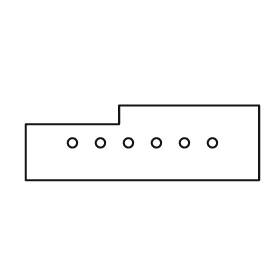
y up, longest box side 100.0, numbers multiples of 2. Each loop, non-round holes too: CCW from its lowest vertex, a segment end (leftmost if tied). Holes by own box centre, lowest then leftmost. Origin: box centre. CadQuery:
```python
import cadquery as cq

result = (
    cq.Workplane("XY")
    .moveTo(-50.0, -16.0)
    .lineTo(50.0, -16.0)
    .lineTo(50.0, 16.0)
    .lineTo(-10.0, 16.0)
    .lineTo(-10.0, 8.0)
    .lineTo(-50.0, 8.0)
    .close()
    .moveTo(-30.0, 0.0)
    .circle(2.0)
    .moveTo(-18.0, 0.0)
    .circle(2.0)
    .moveTo(-6.0, 0.0)
    .circle(2.0)
    .moveTo(6.0, 0.0)
    .circle(2.0)
    .moveTo(18.0, 0.0)
    .circle(2.0)
    .moveTo(30.0, 0.0)
    .circle(2.0)
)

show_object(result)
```